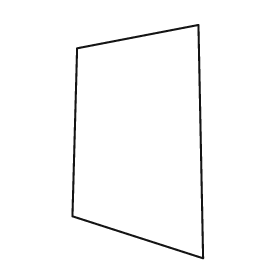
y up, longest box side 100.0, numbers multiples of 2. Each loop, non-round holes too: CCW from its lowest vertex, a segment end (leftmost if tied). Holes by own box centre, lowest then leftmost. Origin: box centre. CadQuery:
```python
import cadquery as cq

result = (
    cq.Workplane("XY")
    .moveTo(28.0, -50.0)
    .lineTo(26.0, 50.0)
    .lineTo(-26.0, 40.0)
    .lineTo(-28.0, -32.0)
    .close()
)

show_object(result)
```